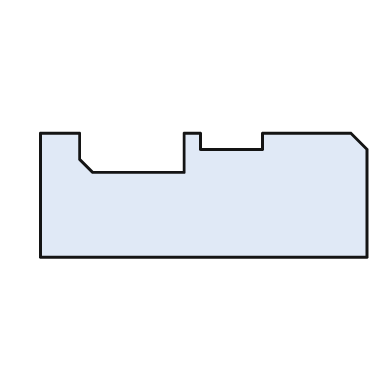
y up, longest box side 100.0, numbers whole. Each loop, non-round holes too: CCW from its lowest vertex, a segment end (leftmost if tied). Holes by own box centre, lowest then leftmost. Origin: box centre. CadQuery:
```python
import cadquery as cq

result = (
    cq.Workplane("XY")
    .moveTo(-50.0, -19.0)
    .lineTo(50.0, -19.0)
    .lineTo(50.0, 14.0)
    .lineTo(45.0, 19.0)
    .lineTo(18.0, 19.0)
    .lineTo(18.0, 14.0)
    .lineTo(-1.0, 14.0)
    .lineTo(-1.0, 19.0)
    .lineTo(-6.0, 19.0)
    .lineTo(-6.0, 7.0)
    .lineTo(-34.0, 7.0)
    .lineTo(-38.0, 11.0)
    .lineTo(-38.0, 19.0)
    .lineTo(-50.0, 19.0)
    .close()
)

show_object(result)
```